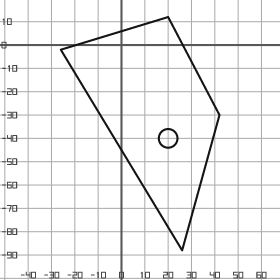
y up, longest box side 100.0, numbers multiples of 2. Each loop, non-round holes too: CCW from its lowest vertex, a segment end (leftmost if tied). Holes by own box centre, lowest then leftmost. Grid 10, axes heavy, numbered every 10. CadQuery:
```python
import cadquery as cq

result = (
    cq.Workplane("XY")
    .moveTo(26.0, -88.0)
    .lineTo(42.0, -30.0)
    .lineTo(20.0, 12.0)
    .lineTo(-26.0, -2.0)
    .close()
    .moveTo(20.0, -40.0)
    .circle(4.0)
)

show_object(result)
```